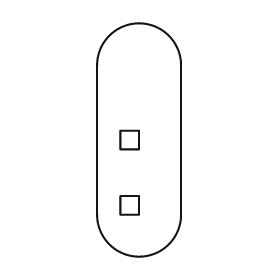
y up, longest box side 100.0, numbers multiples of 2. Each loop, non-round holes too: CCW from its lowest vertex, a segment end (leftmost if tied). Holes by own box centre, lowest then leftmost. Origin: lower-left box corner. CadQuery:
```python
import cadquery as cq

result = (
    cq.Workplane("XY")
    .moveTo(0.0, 18.0)
    .threePointArc((18.0, 0.0), (36.0, 18.0))
    .lineTo(36.0, 82.0)
    .threePointArc((18.0, 100.0), (0.0, 82.0))
    .close()
    .moveTo(10.0, 18.0)
    .lineTo(18.0, 18.0)
    .lineTo(18.0, 26.0)
    .lineTo(10.0, 26.0)
    .close()
    .moveTo(10.0, 46.0)
    .lineTo(18.0, 46.0)
    .lineTo(18.0, 54.0)
    .lineTo(10.0, 54.0)
    .close()
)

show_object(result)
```